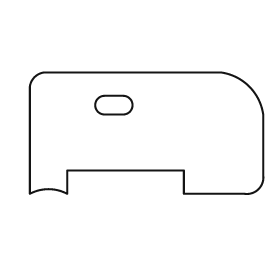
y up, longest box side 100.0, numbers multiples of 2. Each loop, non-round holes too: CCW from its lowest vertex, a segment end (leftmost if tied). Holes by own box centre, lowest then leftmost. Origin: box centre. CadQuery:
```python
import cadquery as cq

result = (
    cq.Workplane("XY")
    .moveTo(-50.0, -26.0)
    .threePointArc((-42.0, -24.0), (-34.0, -26.0))
    .lineTo(-34.0, -16.0)
    .lineTo(16.0, -16.0)
    .lineTo(16.0, -26.0)
    .lineTo(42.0, -26.0)
    .threePointArc((48.0, -24.0), (50.0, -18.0))
    .lineTo(50.0, 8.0)
    .threePointArc((44.0, 20.0), (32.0, 26.0))
    .lineTo(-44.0, 26.0)
    .threePointArc((-48.0, 24.0), (-50.0, 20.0))
    .close()
    .moveTo(-18.0, 8.0)
    .lineTo(-10.0, 8.0)
    .threePointArc((-6.0, 12.0), (-10.0, 16.0))
    .lineTo(-18.0, 16.0)
    .threePointArc((-22.0, 12.0), (-18.0, 8.0))
    .close()
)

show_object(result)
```